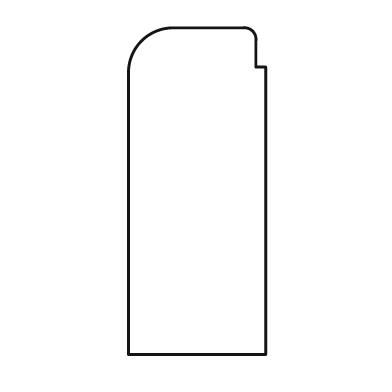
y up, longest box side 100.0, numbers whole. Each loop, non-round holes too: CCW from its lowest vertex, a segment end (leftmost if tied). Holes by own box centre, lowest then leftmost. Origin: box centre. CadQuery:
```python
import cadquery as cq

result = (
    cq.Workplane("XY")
    .moveTo(-21.0, -50.0)
    .lineTo(21.0, -50.0)
    .lineTo(21.0, 38.0)
    .lineTo(18.0, 38.0)
    .lineTo(18.0, 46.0)
    .threePointArc((17.0, 49.0), (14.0, 50.0))
    .lineTo(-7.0, 50.0)
    .threePointArc((-17.0, 46.0), (-21.0, 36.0))
    .close()
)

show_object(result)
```